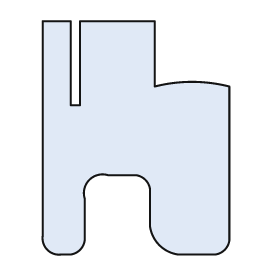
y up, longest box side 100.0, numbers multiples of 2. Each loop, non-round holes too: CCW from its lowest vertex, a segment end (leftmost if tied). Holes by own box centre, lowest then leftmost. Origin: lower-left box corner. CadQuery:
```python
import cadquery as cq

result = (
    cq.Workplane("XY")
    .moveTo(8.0, 0.0)
    .lineTo(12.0, 0.0)
    .threePointArc((16.0, 2.0), (18.0, 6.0))
    .lineTo(18.0, 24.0)
    .threePointArc((20.0, 32.0), (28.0, 34.0))
    .lineTo(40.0, 34.0)
    .threePointArc((44.0, 32.0), (46.0, 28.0))
    .lineTo(46.0, 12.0)
    .threePointArc((50.0, 4.0), (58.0, 0.0))
    .lineTo(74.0, 0.0)
    .threePointArc((78.0, 2.0), (80.0, 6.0))
    .lineTo(80.0, 72.0)
    .threePointArc((64.0, 74.0), (48.0, 72.0))
    .lineTo(48.0, 100.0)
    .lineTo(16.0, 100.0)
    .lineTo(16.0, 64.0)
    .lineTo(12.0, 64.0)
    .lineTo(12.0, 100.0)
    .lineTo(0.0, 100.0)
    .lineTo(0.0, 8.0)
    .threePointArc((2.0, 2.0), (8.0, 0.0))
    .close()
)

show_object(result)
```